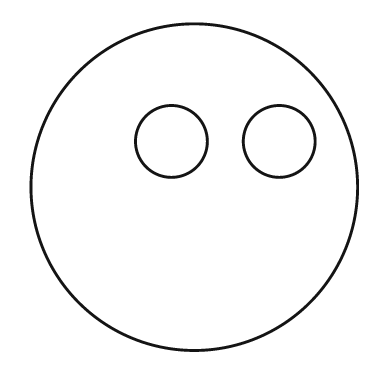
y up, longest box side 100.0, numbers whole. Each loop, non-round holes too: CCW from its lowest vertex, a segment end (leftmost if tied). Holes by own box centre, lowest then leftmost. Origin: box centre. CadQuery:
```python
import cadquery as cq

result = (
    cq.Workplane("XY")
    .moveTo(0.0, 0.0)
    .circle(50.0)
    .moveTo(-7.0, 14.0)
    .circle(11.0)
    .moveTo(26.0, 14.0)
    .circle(11.0)
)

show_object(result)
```